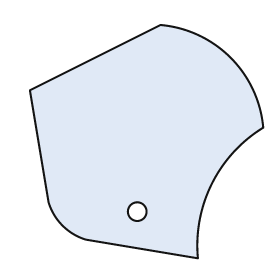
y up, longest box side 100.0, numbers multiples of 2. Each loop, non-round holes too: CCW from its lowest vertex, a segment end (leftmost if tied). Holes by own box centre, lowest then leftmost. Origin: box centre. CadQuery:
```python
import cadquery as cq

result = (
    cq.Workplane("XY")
    .moveTo(22.0, -50.0)
    .threePointArc((28.0, -18.0), (50.0, 6.0))
    .threePointArc((36.0, 36.0), (6.0, 50.0))
    .lineTo(-50.0, 22.0)
    .lineTo(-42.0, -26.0)
    .threePointArc((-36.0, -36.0), (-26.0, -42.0))
    .close()
    .moveTo(-4.0, -30.0)
    .circle(4.0)
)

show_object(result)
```